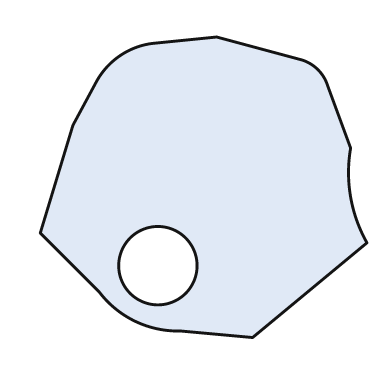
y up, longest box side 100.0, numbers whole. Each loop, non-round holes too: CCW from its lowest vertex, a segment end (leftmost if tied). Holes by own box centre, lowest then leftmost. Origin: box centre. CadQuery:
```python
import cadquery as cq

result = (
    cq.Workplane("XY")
    .moveTo(15.0, -46.0)
    .lineTo(50.0, -17.0)
    .threePointArc((45.0, -3.0), (45.0, 12.0))
    .lineTo(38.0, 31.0)
    .threePointArc((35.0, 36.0), (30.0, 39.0))
    .lineTo(4.0, 46.0)
    .lineTo(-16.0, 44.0)
    .threePointArc((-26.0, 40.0), (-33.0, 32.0))
    .lineTo(-40.0, 19.0)
    .lineTo(-50.0, -14.0)
    .lineTo(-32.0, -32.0)
    .threePointArc((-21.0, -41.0), (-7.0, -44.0))
    .close()
    .moveTo(-14.0, -24.0)
    .circle(12.0)
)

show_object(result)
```